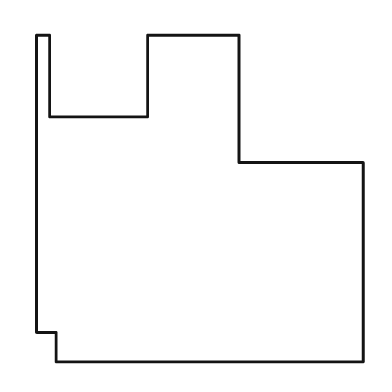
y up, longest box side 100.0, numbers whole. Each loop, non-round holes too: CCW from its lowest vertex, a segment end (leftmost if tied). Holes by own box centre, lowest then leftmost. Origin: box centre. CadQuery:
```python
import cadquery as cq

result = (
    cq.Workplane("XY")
    .moveTo(-44.0, -50.0)
    .lineTo(50.0, -50.0)
    .lineTo(50.0, 11.0)
    .lineTo(12.0, 11.0)
    .lineTo(12.0, 50.0)
    .lineTo(-16.0, 50.0)
    .lineTo(-16.0, 25.0)
    .lineTo(-46.0, 25.0)
    .lineTo(-46.0, 50.0)
    .lineTo(-50.0, 50.0)
    .lineTo(-50.0, -41.0)
    .lineTo(-44.0, -41.0)
    .close()
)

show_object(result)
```